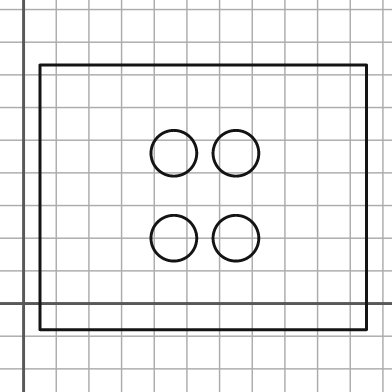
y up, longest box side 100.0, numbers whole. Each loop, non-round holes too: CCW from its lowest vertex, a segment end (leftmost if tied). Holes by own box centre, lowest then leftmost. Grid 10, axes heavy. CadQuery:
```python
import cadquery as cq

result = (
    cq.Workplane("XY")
    .moveTo(5.0, -8.0)
    .lineTo(105.0, -8.0)
    .lineTo(105.0, 73.0)
    .lineTo(5.0, 73.0)
    .close()
    .moveTo(46.0, 20.0)
    .circle(7.0)
    .moveTo(65.0, 20.0)
    .circle(7.0)
    .moveTo(46.0, 46.0)
    .circle(7.0)
    .moveTo(65.0, 46.0)
    .circle(7.0)
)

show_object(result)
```